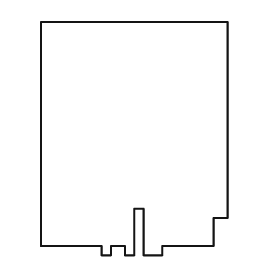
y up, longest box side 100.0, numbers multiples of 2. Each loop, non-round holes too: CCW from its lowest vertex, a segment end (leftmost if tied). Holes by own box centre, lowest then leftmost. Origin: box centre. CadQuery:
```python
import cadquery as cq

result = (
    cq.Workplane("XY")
    .moveTo(-14.0, -50.0)
    .lineTo(-10.0, -50.0)
    .lineTo(-10.0, -46.0)
    .lineTo(-4.0, -46.0)
    .lineTo(-4.0, -50.0)
    .lineTo(0.0, -50.0)
    .lineTo(0.0, -30.0)
    .lineTo(4.0, -30.0)
    .lineTo(4.0, -50.0)
    .lineTo(12.0, -50.0)
    .lineTo(12.0, -46.0)
    .lineTo(34.0, -46.0)
    .lineTo(34.0, -34.0)
    .lineTo(40.0, -34.0)
    .lineTo(40.0, 50.0)
    .lineTo(-40.0, 50.0)
    .lineTo(-40.0, -46.0)
    .lineTo(-14.0, -46.0)
    .close()
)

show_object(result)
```